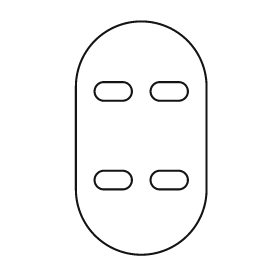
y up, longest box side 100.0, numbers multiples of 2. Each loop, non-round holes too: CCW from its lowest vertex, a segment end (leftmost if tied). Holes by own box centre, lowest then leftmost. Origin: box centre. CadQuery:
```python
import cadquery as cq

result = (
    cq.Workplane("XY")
    .moveTo(-28.0, -22.0)
    .threePointArc((0.0, -50.0), (28.0, -22.0))
    .lineTo(28.0, 22.0)
    .threePointArc((0.0, 50.0), (-28.0, 22.0))
    .close()
    .moveTo(-16.0, -22.0)
    .lineTo(-8.0, -22.0)
    .threePointArc((-4.0, -18.0), (-8.0, -14.0))
    .lineTo(-16.0, -14.0)
    .threePointArc((-20.0, -18.0), (-16.0, -22.0))
    .close()
    .moveTo(8.0, -22.0)
    .lineTo(16.0, -22.0)
    .threePointArc((20.0, -18.0), (16.0, -14.0))
    .lineTo(8.0, -14.0)
    .threePointArc((4.0, -18.0), (8.0, -22.0))
    .close()
    .moveTo(-16.0, 16.0)
    .lineTo(-8.0, 16.0)
    .threePointArc((-4.0, 20.0), (-8.0, 24.0))
    .lineTo(-16.0, 24.0)
    .threePointArc((-20.0, 20.0), (-16.0, 16.0))
    .close()
    .moveTo(8.0, 16.0)
    .lineTo(16.0, 16.0)
    .threePointArc((20.0, 20.0), (16.0, 24.0))
    .lineTo(8.0, 24.0)
    .threePointArc((4.0, 20.0), (8.0, 16.0))
    .close()
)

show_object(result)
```